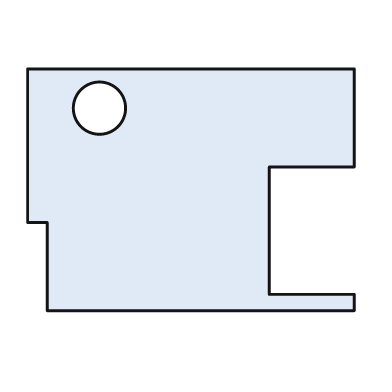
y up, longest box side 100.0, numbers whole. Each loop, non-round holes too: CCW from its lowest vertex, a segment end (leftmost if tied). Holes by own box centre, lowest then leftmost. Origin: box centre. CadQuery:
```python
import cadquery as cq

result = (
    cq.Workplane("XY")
    .moveTo(-44.0, -37.0)
    .lineTo(50.0, -37.0)
    .lineTo(50.0, -32.0)
    .lineTo(24.0, -32.0)
    .lineTo(24.0, 7.0)
    .lineTo(50.0, 7.0)
    .lineTo(50.0, 37.0)
    .lineTo(-50.0, 37.0)
    .lineTo(-50.0, -10.0)
    .lineTo(-44.0, -10.0)
    .close()
    .moveTo(-28.0, 25.0)
    .circle(8.0)
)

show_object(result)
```